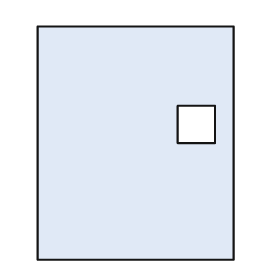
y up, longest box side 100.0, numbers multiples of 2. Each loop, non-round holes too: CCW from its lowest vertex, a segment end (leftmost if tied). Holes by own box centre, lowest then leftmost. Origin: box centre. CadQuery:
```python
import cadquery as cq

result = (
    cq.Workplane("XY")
    .moveTo(-42.0, -50.0)
    .lineTo(42.0, -50.0)
    .lineTo(42.0, 50.0)
    .lineTo(-42.0, 50.0)
    .close()
    .moveTo(18.0, 0.0)
    .lineTo(34.0, 0.0)
    .lineTo(34.0, 16.0)
    .lineTo(18.0, 16.0)
    .close()
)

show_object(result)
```